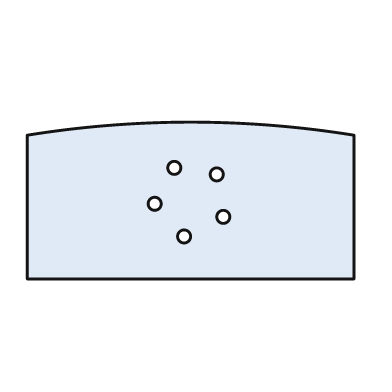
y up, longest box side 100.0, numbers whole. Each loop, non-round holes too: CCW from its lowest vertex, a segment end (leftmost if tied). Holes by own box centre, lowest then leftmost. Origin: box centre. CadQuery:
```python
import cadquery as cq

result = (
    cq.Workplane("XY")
    .moveTo(-50.0, -24.0)
    .lineTo(50.0, -24.0)
    .lineTo(50.0, 20.0)
    .threePointArc((0.0, 24.0), (-50.0, 20.0))
    .close()
    .moveTo(-2.0, -11.0)
    .circle(2.0)
    .moveTo(10.0, -5.0)
    .circle(2.0)
    .moveTo(-11.0, -1.0)
    .circle(2.0)
    .moveTo(8.0, 8.0)
    .circle(2.0)
    .moveTo(-5.0, 10.0)
    .circle(2.0)
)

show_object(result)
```